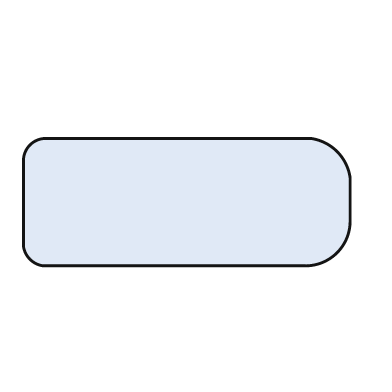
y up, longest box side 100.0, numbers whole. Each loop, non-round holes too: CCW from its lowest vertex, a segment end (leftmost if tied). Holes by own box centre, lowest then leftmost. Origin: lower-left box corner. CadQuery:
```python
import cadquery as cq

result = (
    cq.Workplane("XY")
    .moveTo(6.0, 0.0)
    .lineTo(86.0, 0.0)
    .threePointArc((96.0, 4.0), (100.0, 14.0))
    .lineTo(100.0, 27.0)
    .threePointArc((96.0, 35.0), (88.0, 39.0))
    .lineTo(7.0, 39.0)
    .threePointArc((2.0, 37.0), (0.0, 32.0))
    .lineTo(0.0, 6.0)
    .threePointArc((2.0, 2.0), (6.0, 0.0))
    .close()
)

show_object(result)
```